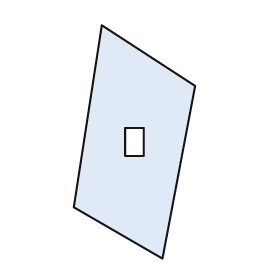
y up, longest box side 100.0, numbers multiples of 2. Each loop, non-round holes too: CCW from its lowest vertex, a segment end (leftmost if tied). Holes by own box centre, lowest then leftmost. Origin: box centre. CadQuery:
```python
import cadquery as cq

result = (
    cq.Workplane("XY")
    .moveTo(12.0, -50.0)
    .lineTo(26.0, 24.0)
    .lineTo(-14.0, 50.0)
    .lineTo(-26.0, -28.0)
    .close()
    .moveTo(-4.0, -6.0)
    .lineTo(4.0, -6.0)
    .lineTo(4.0, 6.0)
    .lineTo(-4.0, 6.0)
    .close()
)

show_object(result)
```